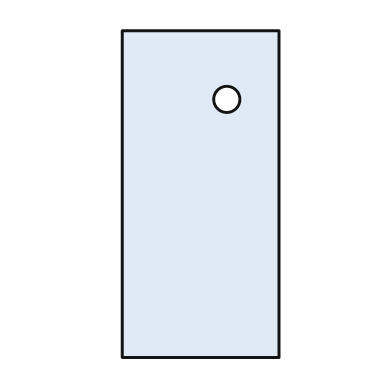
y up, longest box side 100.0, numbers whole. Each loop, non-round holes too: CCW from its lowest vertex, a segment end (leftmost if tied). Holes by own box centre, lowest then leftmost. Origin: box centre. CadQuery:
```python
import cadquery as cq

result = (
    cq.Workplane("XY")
    .moveTo(-24.0, -50.0)
    .lineTo(24.0, -50.0)
    .lineTo(24.0, 50.0)
    .lineTo(-24.0, 50.0)
    .close()
    .moveTo(8.0, 29.0)
    .circle(4.0)
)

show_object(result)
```